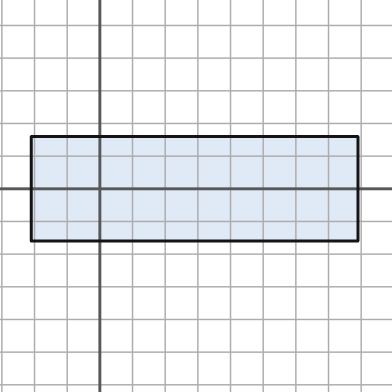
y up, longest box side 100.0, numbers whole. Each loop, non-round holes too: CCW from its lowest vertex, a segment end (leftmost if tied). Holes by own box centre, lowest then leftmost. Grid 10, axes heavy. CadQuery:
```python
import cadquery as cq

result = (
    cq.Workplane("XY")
    .moveTo(-21.0, -16.0)
    .lineTo(79.0, -16.0)
    .lineTo(79.0, 16.0)
    .lineTo(-21.0, 16.0)
    .close()
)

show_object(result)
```